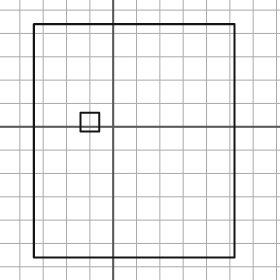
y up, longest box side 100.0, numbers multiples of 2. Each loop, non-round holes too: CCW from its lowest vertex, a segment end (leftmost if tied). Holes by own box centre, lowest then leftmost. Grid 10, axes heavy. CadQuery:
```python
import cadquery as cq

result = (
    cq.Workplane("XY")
    .moveTo(-34.0, -56.0)
    .lineTo(52.0, -56.0)
    .lineTo(52.0, 44.0)
    .lineTo(-34.0, 44.0)
    .close()
    .moveTo(-14.0, -2.0)
    .lineTo(-6.0, -2.0)
    .lineTo(-6.0, 6.0)
    .lineTo(-14.0, 6.0)
    .close()
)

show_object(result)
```